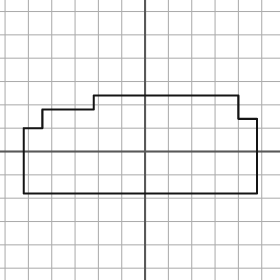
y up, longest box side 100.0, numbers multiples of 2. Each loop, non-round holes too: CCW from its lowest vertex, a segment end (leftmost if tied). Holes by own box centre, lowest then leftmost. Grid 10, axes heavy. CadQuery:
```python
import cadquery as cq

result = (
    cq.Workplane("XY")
    .moveTo(-52.0, -18.0)
    .lineTo(48.0, -18.0)
    .lineTo(48.0, 14.0)
    .lineTo(40.0, 14.0)
    .lineTo(40.0, 24.0)
    .lineTo(-22.0, 24.0)
    .lineTo(-22.0, 18.0)
    .lineTo(-44.0, 18.0)
    .lineTo(-44.0, 10.0)
    .lineTo(-52.0, 10.0)
    .close()
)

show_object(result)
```